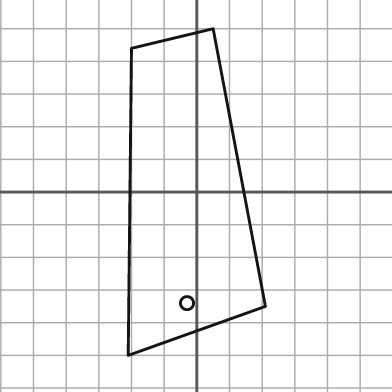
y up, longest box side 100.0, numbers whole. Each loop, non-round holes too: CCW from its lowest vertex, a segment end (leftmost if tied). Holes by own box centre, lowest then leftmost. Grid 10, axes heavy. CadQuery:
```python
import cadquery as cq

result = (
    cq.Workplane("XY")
    .moveTo(-21.0, -50.0)
    .lineTo(21.0, -35.0)
    .lineTo(5.0, 50.0)
    .lineTo(-20.0, 44.0)
    .close()
    .moveTo(-3.0, -34.0)
    .circle(2.0)
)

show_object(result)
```